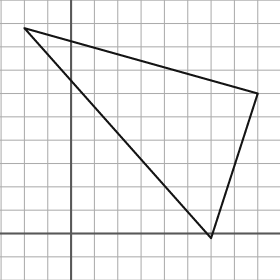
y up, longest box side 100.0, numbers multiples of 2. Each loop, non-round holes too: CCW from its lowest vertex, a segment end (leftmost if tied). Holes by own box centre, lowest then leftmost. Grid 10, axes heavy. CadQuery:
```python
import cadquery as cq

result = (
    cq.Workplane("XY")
    .moveTo(60.0, -2.0)
    .lineTo(80.0, 60.0)
    .lineTo(-20.0, 88.0)
    .close()
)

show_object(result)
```